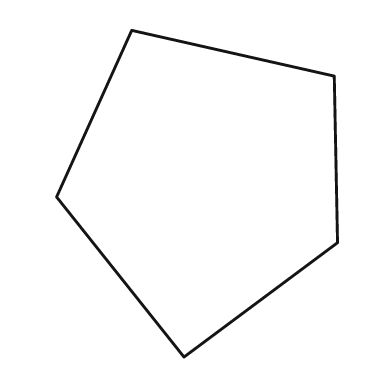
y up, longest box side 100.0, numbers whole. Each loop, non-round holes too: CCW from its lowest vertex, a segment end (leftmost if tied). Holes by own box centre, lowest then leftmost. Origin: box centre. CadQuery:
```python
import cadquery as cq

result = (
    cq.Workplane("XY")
    .moveTo(-4.0, -50.0)
    .lineTo(43.0, -15.0)
    .lineTo(42.0, 36.0)
    .lineTo(-20.0, 50.0)
    .lineTo(-43.0, -1.0)
    .close()
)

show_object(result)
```